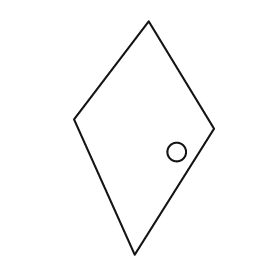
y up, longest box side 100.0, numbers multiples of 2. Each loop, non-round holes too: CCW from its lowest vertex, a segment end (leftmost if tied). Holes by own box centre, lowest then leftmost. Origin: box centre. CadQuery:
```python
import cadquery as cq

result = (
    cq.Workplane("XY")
    .moveTo(-4.0, -50.0)
    .lineTo(30.0, 4.0)
    .lineTo(2.0, 50.0)
    .lineTo(-30.0, 8.0)
    .close()
    .moveTo(14.0, -6.0)
    .circle(4.0)
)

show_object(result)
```